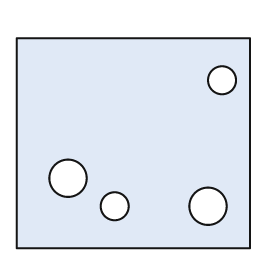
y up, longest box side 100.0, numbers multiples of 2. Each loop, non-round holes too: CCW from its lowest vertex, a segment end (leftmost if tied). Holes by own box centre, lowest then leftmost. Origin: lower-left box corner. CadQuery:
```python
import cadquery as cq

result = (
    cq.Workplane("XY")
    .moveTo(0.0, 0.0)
    .lineTo(100.0, 0.0)
    .lineTo(100.0, 90.0)
    .lineTo(0.0, 90.0)
    .close()
    .moveTo(42.0, 18.0)
    .circle(6.0)
    .moveTo(82.0, 18.0)
    .circle(8.0)
    .moveTo(22.0, 30.0)
    .circle(8.0)
    .moveTo(88.0, 72.0)
    .circle(6.0)
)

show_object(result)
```